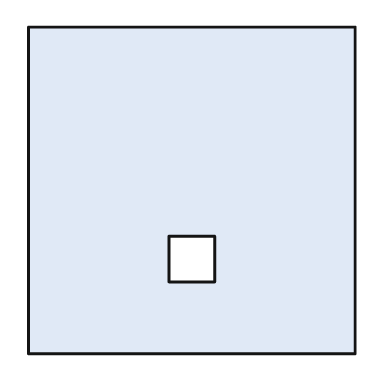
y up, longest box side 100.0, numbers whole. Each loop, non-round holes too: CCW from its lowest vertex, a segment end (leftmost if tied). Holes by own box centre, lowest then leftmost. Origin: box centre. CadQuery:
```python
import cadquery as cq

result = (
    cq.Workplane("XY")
    .moveTo(-50.0, -50.0)
    .lineTo(50.0, -50.0)
    .lineTo(50.0, 50.0)
    .lineTo(-50.0, 50.0)
    .close()
    .moveTo(-7.0, -28.0)
    .lineTo(7.0, -28.0)
    .lineTo(7.0, -14.0)
    .lineTo(-7.0, -14.0)
    .close()
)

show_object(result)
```